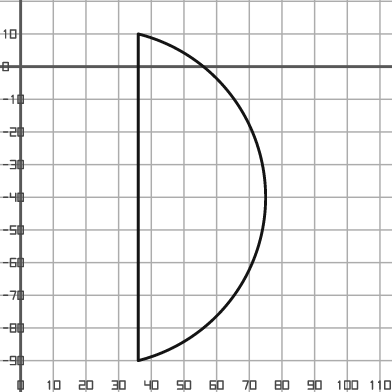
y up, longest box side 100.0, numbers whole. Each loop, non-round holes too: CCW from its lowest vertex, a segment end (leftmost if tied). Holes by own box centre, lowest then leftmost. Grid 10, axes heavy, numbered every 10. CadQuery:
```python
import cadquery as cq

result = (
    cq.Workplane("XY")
    .moveTo(36.0, -90.0)
    .threePointArc((75.0, -40.0), (36.0, 10.0))
    .close()
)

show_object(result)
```